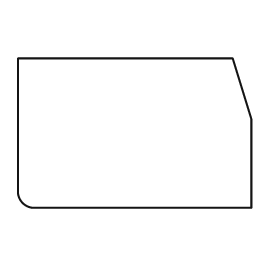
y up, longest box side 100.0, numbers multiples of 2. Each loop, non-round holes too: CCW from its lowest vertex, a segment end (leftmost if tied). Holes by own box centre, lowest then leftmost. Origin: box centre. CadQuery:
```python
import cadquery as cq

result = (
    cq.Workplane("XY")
    .moveTo(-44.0, -32.0)
    .lineTo(50.0, -32.0)
    .lineTo(50.0, 6.0)
    .lineTo(42.0, 32.0)
    .lineTo(-50.0, 32.0)
    .lineTo(-50.0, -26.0)
    .threePointArc((-48.0, -30.0), (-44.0, -32.0))
    .close()
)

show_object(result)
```